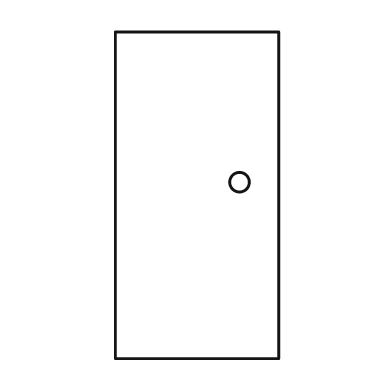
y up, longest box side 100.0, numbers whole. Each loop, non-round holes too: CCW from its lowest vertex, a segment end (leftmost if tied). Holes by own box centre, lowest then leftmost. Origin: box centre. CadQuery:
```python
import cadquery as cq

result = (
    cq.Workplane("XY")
    .moveTo(-25.0, -50.0)
    .lineTo(25.0, -50.0)
    .lineTo(25.0, 50.0)
    .lineTo(-25.0, 50.0)
    .close()
    .moveTo(13.0, 4.0)
    .circle(3.0)
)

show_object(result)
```